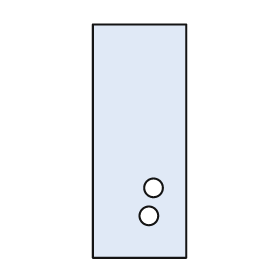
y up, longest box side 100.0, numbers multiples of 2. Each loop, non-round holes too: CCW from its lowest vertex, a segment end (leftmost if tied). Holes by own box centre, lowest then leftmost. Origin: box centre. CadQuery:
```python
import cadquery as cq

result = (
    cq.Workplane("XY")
    .moveTo(-20.0, -50.0)
    .lineTo(20.0, -50.0)
    .lineTo(20.0, 50.0)
    .lineTo(-20.0, 50.0)
    .close()
    .moveTo(4.0, -32.0)
    .circle(4.0)
    .moveTo(6.0, -20.0)
    .circle(4.0)
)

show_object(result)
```